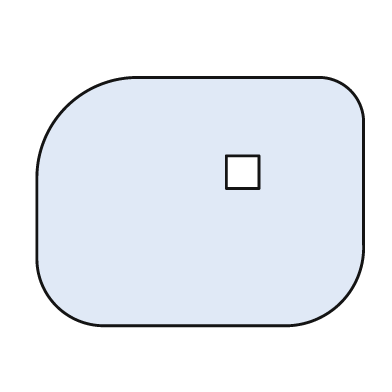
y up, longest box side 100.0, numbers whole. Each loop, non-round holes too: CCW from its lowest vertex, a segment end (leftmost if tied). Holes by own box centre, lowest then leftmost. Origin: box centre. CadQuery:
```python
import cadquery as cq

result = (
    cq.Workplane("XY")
    .moveTo(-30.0, -38.0)
    .lineTo(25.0, -38.0)
    .threePointArc((43.0, -31.0), (50.0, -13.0))
    .lineTo(50.0, 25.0)
    .threePointArc((46.0, 34.0), (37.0, 38.0))
    .lineTo(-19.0, 38.0)
    .threePointArc((-41.0, 29.0), (-50.0, 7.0))
    .lineTo(-50.0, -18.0)
    .threePointArc((-44.0, -32.0), (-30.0, -38.0))
    .close()
    .moveTo(8.0, 4.0)
    .lineTo(18.0, 4.0)
    .lineTo(18.0, 14.0)
    .lineTo(8.0, 14.0)
    .close()
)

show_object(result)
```